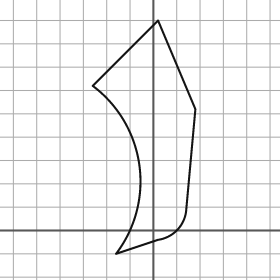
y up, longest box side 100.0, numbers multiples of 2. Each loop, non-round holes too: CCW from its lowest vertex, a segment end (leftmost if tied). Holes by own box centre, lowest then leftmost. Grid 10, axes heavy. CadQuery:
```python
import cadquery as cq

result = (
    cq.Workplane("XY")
    .moveTo(-16.0, -10.0)
    .lineTo(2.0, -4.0)
    .threePointArc((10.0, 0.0), (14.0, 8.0))
    .lineTo(18.0, 52.0)
    .lineTo(2.0, 90.0)
    .lineTo(-26.0, 62.0)
    .threePointArc((-6.0, 28.0), (-16.0, -10.0))
    .close()
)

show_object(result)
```